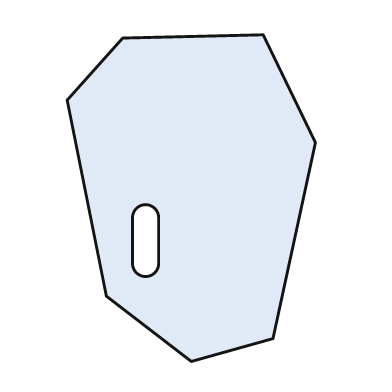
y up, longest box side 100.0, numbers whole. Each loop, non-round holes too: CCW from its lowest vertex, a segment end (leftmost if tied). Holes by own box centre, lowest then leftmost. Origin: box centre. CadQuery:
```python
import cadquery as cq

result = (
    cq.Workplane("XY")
    .moveTo(0.0, -50.0)
    .lineTo(25.0, -43.0)
    .lineTo(38.0, 17.0)
    .lineTo(22.0, 50.0)
    .lineTo(-21.0, 49.0)
    .lineTo(-38.0, 30.0)
    .lineTo(-26.0, -30.0)
    .close()
    .moveTo(-18.0, -20.0)
    .threePointArc((-14.0, -24.0), (-10.0, -20.0))
    .lineTo(-10.0, -6.0)
    .threePointArc((-14.0, -2.0), (-18.0, -6.0))
    .close()
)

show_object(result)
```